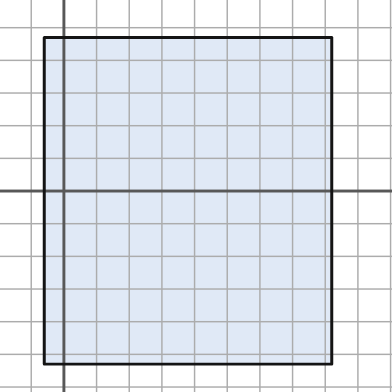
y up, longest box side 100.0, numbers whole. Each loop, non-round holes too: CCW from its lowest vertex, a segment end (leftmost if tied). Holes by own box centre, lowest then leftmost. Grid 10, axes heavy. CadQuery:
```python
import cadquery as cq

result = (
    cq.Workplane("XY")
    .moveTo(-6.0, -53.0)
    .lineTo(82.0, -53.0)
    .lineTo(82.0, 47.0)
    .lineTo(-6.0, 47.0)
    .close()
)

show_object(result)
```